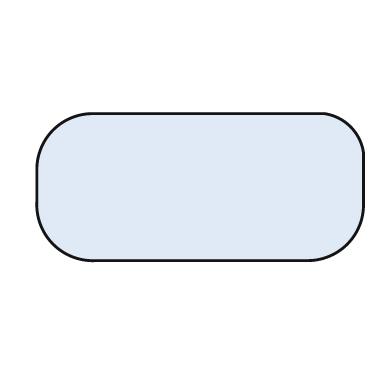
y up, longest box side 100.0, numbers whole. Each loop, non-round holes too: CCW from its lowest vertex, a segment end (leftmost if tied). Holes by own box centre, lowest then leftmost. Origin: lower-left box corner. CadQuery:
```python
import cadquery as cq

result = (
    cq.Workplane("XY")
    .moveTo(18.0, 0.0)
    .lineTo(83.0, 0.0)
    .threePointArc((95.0, 5.0), (100.0, 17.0))
    .lineTo(100.0, 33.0)
    .threePointArc((96.0, 41.0), (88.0, 45.0))
    .lineTo(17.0, 45.0)
    .threePointArc((5.0, 40.0), (0.0, 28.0))
    .lineTo(0.0, 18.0)
    .threePointArc((5.0, 5.0), (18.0, 0.0))
    .close()
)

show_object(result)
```